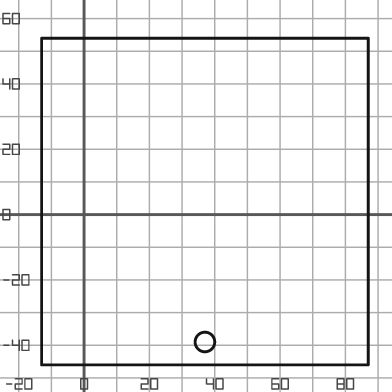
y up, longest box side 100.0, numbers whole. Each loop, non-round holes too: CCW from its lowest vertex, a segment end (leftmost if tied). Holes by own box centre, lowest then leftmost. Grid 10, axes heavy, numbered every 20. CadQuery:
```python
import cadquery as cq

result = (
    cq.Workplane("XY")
    .moveTo(-13.0, -46.0)
    .lineTo(87.0, -46.0)
    .lineTo(87.0, 54.0)
    .lineTo(-13.0, 54.0)
    .close()
    .moveTo(37.0, -39.0)
    .circle(3.0)
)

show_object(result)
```